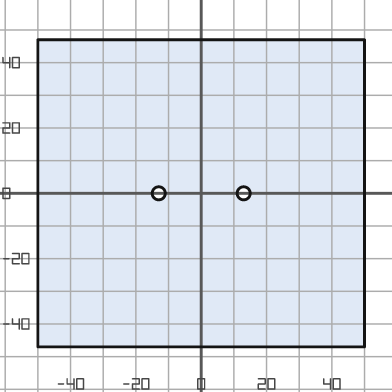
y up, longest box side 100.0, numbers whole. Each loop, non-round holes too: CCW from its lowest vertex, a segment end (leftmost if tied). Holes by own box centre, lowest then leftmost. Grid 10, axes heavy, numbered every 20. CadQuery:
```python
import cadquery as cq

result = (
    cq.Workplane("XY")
    .moveTo(-50.0, -47.0)
    .lineTo(50.0, -47.0)
    .lineTo(50.0, 47.0)
    .lineTo(-50.0, 47.0)
    .close()
    .moveTo(-13.0, 0.0)
    .circle(2.0)
    .moveTo(13.0, 0.0)
    .circle(2.0)
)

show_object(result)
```